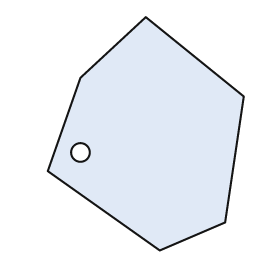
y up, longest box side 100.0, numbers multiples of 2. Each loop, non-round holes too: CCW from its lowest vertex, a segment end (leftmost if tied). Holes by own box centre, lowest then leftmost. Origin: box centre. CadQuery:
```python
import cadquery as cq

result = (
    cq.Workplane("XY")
    .moveTo(6.0, -50.0)
    .lineTo(34.0, -38.0)
    .lineTo(42.0, 16.0)
    .lineTo(0.0, 50.0)
    .lineTo(-28.0, 24.0)
    .lineTo(-42.0, -16.0)
    .close()
    .moveTo(-28.0, -8.0)
    .circle(4.0)
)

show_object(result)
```